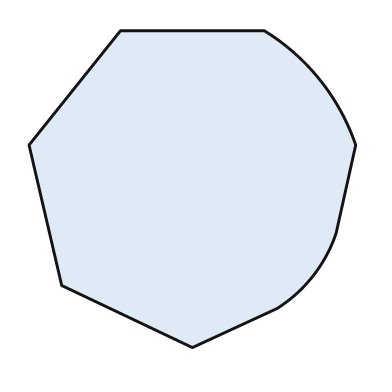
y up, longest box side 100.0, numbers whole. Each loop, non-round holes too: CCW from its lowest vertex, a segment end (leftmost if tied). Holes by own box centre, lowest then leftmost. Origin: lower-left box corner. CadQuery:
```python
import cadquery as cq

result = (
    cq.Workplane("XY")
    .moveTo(50.0, 0.0)
    .lineTo(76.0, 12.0)
    .threePointArc((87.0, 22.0), (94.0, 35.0))
    .lineTo(100.0, 62.0)
    .threePointArc((89.0, 82.0), (72.0, 97.0))
    .lineTo(28.0, 97.0)
    .lineTo(0.0, 62.0)
    .lineTo(10.0, 19.0)
    .close()
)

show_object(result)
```